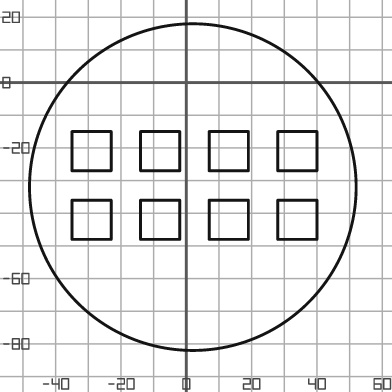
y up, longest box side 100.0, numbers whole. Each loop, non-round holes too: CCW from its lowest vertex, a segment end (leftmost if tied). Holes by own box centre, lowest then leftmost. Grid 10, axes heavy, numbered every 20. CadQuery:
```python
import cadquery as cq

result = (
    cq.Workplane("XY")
    .moveTo(2.0, -32.0)
    .circle(50.0)
    .moveTo(-35.0, -48.0)
    .lineTo(-23.0, -48.0)
    .lineTo(-23.0, -36.0)
    .lineTo(-35.0, -36.0)
    .close()
    .moveTo(-14.0, -48.0)
    .lineTo(-2.0, -48.0)
    .lineTo(-2.0, -36.0)
    .lineTo(-14.0, -36.0)
    .close()
    .moveTo(7.0, -48.0)
    .lineTo(19.0, -48.0)
    .lineTo(19.0, -36.0)
    .lineTo(7.0, -36.0)
    .close()
    .moveTo(28.0, -48.0)
    .lineTo(40.0, -48.0)
    .lineTo(40.0, -36.0)
    .lineTo(28.0, -36.0)
    .close()
    .moveTo(-35.0, -27.0)
    .lineTo(-23.0, -27.0)
    .lineTo(-23.0, -15.0)
    .lineTo(-35.0, -15.0)
    .close()
    .moveTo(-14.0, -27.0)
    .lineTo(-2.0, -27.0)
    .lineTo(-2.0, -15.0)
    .lineTo(-14.0, -15.0)
    .close()
    .moveTo(7.0, -27.0)
    .lineTo(19.0, -27.0)
    .lineTo(19.0, -15.0)
    .lineTo(7.0, -15.0)
    .close()
    .moveTo(28.0, -27.0)
    .lineTo(40.0, -27.0)
    .lineTo(40.0, -15.0)
    .lineTo(28.0, -15.0)
    .close()
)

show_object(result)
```